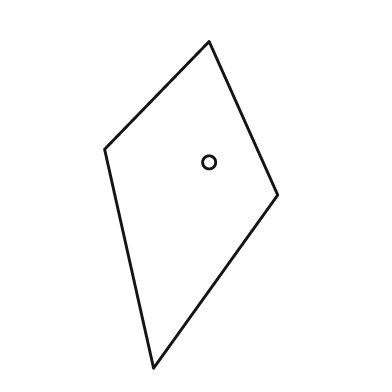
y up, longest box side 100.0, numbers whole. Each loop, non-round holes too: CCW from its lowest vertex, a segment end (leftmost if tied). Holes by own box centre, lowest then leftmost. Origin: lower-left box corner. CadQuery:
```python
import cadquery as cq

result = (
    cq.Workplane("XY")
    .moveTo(15.0, 0.0)
    .lineTo(53.0, 53.0)
    .lineTo(32.0, 100.0)
    .lineTo(0.0, 67.0)
    .close()
    .moveTo(32.0, 63.0)
    .circle(2.0)
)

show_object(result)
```